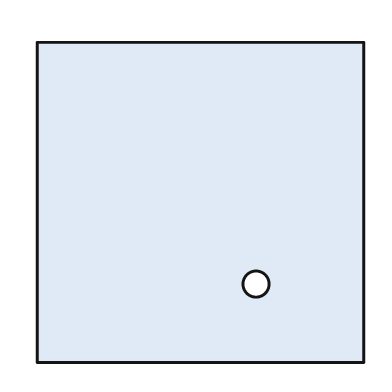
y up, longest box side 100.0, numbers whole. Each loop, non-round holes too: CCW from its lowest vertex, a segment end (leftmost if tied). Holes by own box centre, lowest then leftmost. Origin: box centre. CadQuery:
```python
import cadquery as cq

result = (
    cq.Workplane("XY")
    .moveTo(-50.0, -49.0)
    .lineTo(50.0, -49.0)
    .lineTo(50.0, 49.0)
    .lineTo(-50.0, 49.0)
    .close()
    .moveTo(17.0, -25.0)
    .circle(4.0)
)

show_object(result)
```